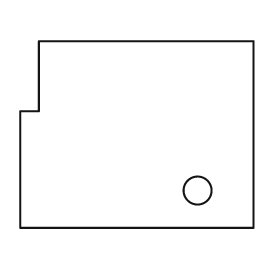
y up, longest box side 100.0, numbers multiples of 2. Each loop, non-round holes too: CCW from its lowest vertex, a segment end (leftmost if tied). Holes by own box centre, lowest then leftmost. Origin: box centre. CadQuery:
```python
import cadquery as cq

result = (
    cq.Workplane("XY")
    .moveTo(-50.0, -40.0)
    .lineTo(50.0, -40.0)
    .lineTo(50.0, 40.0)
    .lineTo(-42.0, 40.0)
    .lineTo(-42.0, 10.0)
    .lineTo(-50.0, 10.0)
    .close()
    .moveTo(26.0, -24.0)
    .circle(6.0)
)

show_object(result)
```